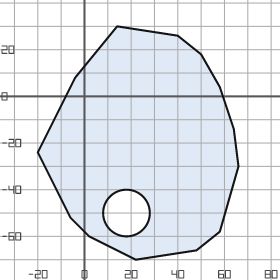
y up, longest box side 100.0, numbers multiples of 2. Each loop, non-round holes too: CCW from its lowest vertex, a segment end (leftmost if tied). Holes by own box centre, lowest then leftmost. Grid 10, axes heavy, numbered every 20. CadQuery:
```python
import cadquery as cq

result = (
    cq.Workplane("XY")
    .moveTo(22.0, -70.0)
    .lineTo(48.0, -66.0)
    .lineTo(58.0, -58.0)
    .lineTo(66.0, -30.0)
    .lineTo(64.0, -14.0)
    .lineTo(58.0, 4.0)
    .lineTo(50.0, 18.0)
    .lineTo(40.0, 26.0)
    .lineTo(14.0, 30.0)
    .lineTo(-4.0, 8.0)
    .lineTo(-20.0, -24.0)
    .lineTo(-6.0, -52.0)
    .lineTo(2.0, -60.0)
    .close()
    .moveTo(18.0, -50.0)
    .circle(10.0)
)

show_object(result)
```